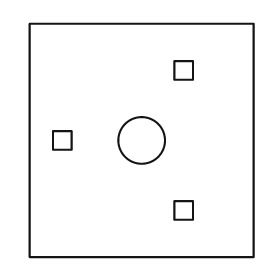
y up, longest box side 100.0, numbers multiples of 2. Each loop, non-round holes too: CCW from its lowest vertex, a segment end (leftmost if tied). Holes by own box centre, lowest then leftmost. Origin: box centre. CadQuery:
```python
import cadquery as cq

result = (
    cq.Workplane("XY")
    .moveTo(-48.0, -50.0)
    .lineTo(48.0, -50.0)
    .lineTo(48.0, 50.0)
    .lineTo(-48.0, 50.0)
    .close()
    .moveTo(14.0, -34.0)
    .lineTo(22.0, -34.0)
    .lineTo(22.0, -26.0)
    .lineTo(14.0, -26.0)
    .close()
    .moveTo(-38.0, -4.0)
    .lineTo(-30.0, -4.0)
    .lineTo(-30.0, 4.0)
    .lineTo(-38.0, 4.0)
    .close()
    .moveTo(0.0, 0.0)
    .circle(10.0)
    .moveTo(14.0, 26.0)
    .lineTo(22.0, 26.0)
    .lineTo(22.0, 34.0)
    .lineTo(14.0, 34.0)
    .close()
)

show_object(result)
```